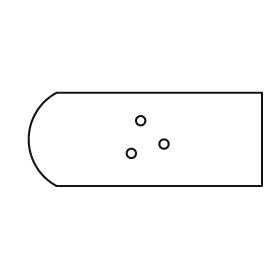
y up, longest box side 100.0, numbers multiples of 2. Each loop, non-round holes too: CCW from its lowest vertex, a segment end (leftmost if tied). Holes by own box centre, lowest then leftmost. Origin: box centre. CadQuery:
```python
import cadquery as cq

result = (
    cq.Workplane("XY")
    .moveTo(-38.0, -20.0)
    .lineTo(50.0, -20.0)
    .lineTo(50.0, 20.0)
    .lineTo(-38.0, 20.0)
    .threePointArc((-50.0, 0.0), (-38.0, -20.0))
    .close()
    .moveTo(-6.0, -6.0)
    .circle(2.0)
    .moveTo(8.0, -2.0)
    .circle(2.0)
    .moveTo(-2.0, 8.0)
    .circle(2.0)
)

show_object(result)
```